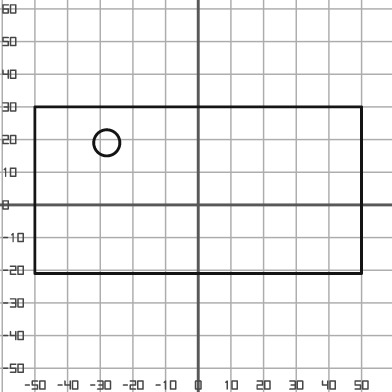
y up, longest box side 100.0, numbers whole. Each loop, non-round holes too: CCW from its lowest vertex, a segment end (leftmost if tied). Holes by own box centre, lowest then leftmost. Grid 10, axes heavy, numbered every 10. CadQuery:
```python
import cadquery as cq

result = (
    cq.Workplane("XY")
    .moveTo(-50.0, -21.0)
    .lineTo(50.0, -21.0)
    .lineTo(50.0, 30.0)
    .lineTo(-50.0, 30.0)
    .close()
    .moveTo(-28.0, 19.0)
    .circle(4.0)
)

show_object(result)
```